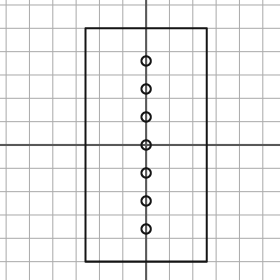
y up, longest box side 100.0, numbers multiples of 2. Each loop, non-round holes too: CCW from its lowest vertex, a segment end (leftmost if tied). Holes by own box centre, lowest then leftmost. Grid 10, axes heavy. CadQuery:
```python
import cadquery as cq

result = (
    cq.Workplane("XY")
    .moveTo(-26.0, -50.0)
    .lineTo(26.0, -50.0)
    .lineTo(26.0, 50.0)
    .lineTo(-26.0, 50.0)
    .close()
    .moveTo(0.0, -36.0)
    .circle(2.0)
    .moveTo(0.0, -24.0)
    .circle(2.0)
    .moveTo(0.0, -12.0)
    .circle(2.0)
    .moveTo(0.0, 0.0)
    .circle(2.0)
    .moveTo(0.0, 12.0)
    .circle(2.0)
    .moveTo(0.0, 24.0)
    .circle(2.0)
    .moveTo(0.0, 36.0)
    .circle(2.0)
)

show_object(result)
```